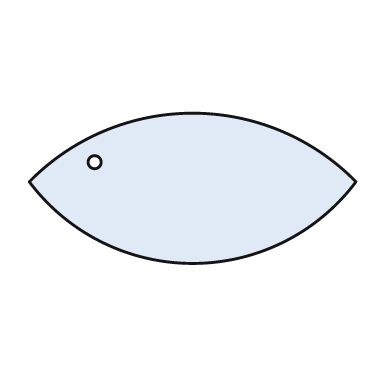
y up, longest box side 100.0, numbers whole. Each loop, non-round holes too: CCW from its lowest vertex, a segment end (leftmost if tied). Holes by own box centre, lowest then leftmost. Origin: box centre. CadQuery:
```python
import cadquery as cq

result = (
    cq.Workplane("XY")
    .moveTo(-50.0, 2.0)
    .threePointArc((0.0, -23.0), (50.0, 2.0))
    .threePointArc((0.0, 23.0), (-50.0, 2.0))
    .close()
    .moveTo(-30.0, 8.0)
    .circle(2.0)
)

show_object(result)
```